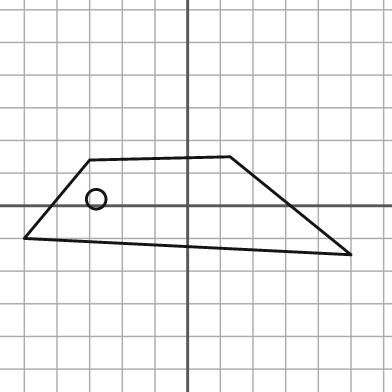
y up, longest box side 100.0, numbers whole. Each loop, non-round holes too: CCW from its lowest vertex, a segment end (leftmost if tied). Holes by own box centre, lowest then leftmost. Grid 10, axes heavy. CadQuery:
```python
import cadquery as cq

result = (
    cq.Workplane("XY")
    .moveTo(50.0, -15.0)
    .lineTo(13.0, 15.0)
    .lineTo(-30.0, 14.0)
    .lineTo(-50.0, -10.0)
    .close()
    .moveTo(-28.0, 2.0)
    .circle(3.0)
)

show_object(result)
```